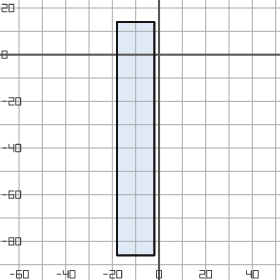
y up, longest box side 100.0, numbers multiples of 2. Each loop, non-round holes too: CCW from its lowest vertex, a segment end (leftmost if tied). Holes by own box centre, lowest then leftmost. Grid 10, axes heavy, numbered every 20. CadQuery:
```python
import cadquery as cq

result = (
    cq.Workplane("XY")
    .moveTo(-18.0, -86.0)
    .lineTo(-2.0, -86.0)
    .lineTo(-2.0, 14.0)
    .lineTo(-18.0, 14.0)
    .close()
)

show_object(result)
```